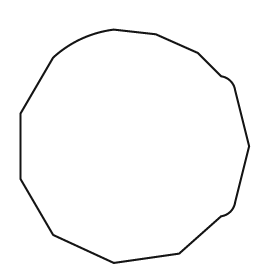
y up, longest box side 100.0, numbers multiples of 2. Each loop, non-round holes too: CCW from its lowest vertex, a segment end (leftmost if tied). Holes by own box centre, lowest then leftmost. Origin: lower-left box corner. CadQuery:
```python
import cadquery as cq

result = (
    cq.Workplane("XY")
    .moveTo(40.0, 0.0)
    .lineTo(68.0, 4.0)
    .lineTo(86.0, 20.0)
    .threePointArc((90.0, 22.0), (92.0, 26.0))
    .lineTo(98.0, 50.0)
    .lineTo(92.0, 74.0)
    .threePointArc((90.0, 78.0), (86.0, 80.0))
    .lineTo(76.0, 90.0)
    .lineTo(58.0, 98.0)
    .lineTo(40.0, 100.0)
    .threePointArc((26.0, 96.0), (14.0, 88.0))
    .lineTo(0.0, 64.0)
    .lineTo(0.0, 36.0)
    .lineTo(14.0, 12.0)
    .close()
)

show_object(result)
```